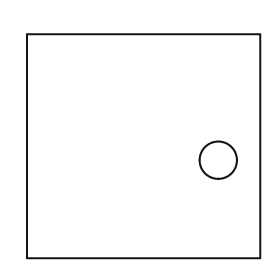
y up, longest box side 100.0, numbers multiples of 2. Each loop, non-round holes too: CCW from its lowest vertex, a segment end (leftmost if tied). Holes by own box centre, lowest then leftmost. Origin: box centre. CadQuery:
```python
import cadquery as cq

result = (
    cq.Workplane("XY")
    .moveTo(-50.0, -48.0)
    .lineTo(50.0, -48.0)
    .lineTo(50.0, 48.0)
    .lineTo(-50.0, 48.0)
    .close()
    .moveTo(32.0, -6.0)
    .circle(8.0)
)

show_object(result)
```